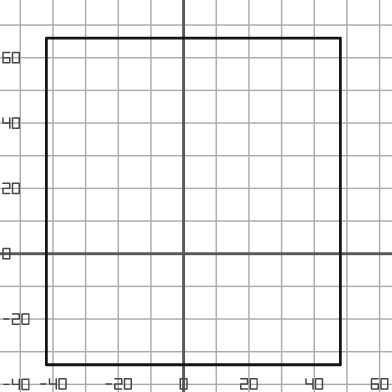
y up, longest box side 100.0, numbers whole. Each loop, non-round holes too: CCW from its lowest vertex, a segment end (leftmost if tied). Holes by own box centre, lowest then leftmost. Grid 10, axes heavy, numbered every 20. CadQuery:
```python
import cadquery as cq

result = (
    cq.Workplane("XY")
    .moveTo(-42.0, -34.0)
    .lineTo(48.0, -34.0)
    .lineTo(48.0, 66.0)
    .lineTo(-42.0, 66.0)
    .close()
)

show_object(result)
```